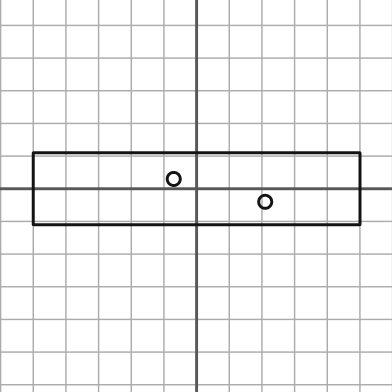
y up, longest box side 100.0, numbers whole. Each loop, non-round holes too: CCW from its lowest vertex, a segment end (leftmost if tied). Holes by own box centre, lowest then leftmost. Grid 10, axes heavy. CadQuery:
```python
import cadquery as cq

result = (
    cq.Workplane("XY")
    .moveTo(-50.0, -11.0)
    .lineTo(50.0, -11.0)
    .lineTo(50.0, 11.0)
    .lineTo(-50.0, 11.0)
    .close()
    .moveTo(21.0, -4.0)
    .circle(2.0)
    .moveTo(-7.0, 3.0)
    .circle(2.0)
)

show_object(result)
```